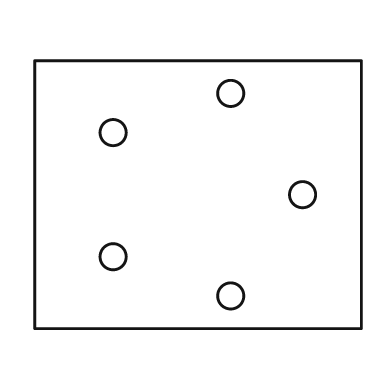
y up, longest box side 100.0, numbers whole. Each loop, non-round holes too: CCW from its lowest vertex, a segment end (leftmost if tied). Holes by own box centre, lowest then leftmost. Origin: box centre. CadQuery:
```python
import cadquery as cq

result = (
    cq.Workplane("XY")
    .moveTo(-50.0, -41.0)
    .lineTo(50.0, -41.0)
    .lineTo(50.0, 41.0)
    .lineTo(-50.0, 41.0)
    .close()
    .moveTo(10.0, -31.0)
    .circle(4.0)
    .moveTo(-26.0, -19.0)
    .circle(4.0)
    .moveTo(32.0, 0.0)
    .circle(4.0)
    .moveTo(-26.0, 19.0)
    .circle(4.0)
    .moveTo(10.0, 31.0)
    .circle(4.0)
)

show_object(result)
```